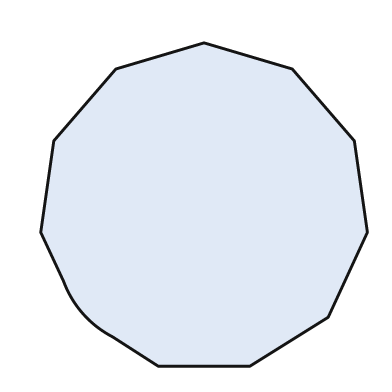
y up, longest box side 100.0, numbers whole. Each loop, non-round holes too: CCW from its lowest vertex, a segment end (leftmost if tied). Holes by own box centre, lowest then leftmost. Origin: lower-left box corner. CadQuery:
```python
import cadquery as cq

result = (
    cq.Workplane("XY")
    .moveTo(36.0, 0.0)
    .lineTo(64.0, 0.0)
    .lineTo(88.0, 15.0)
    .lineTo(100.0, 41.0)
    .lineTo(96.0, 69.0)
    .lineTo(77.0, 91.0)
    .lineTo(50.0, 99.0)
    .lineTo(23.0, 91.0)
    .lineTo(4.0, 69.0)
    .lineTo(0.0, 41.0)
    .lineTo(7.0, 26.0)
    .threePointArc((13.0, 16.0), (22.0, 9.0))
    .close()
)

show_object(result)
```